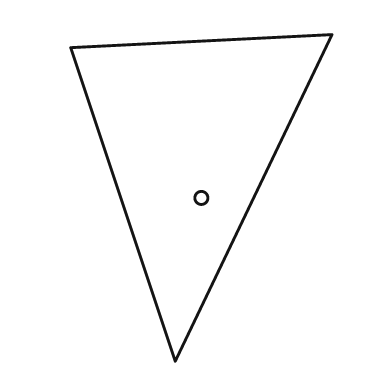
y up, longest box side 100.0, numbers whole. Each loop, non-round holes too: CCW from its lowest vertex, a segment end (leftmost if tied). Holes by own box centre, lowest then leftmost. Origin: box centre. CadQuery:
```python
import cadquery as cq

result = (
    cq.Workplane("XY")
    .moveTo(-8.0, -50.0)
    .lineTo(40.0, 50.0)
    .lineTo(-40.0, 46.0)
    .close()
    .moveTo(0.0, 0.0)
    .circle(2.0)
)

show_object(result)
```